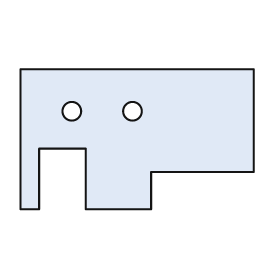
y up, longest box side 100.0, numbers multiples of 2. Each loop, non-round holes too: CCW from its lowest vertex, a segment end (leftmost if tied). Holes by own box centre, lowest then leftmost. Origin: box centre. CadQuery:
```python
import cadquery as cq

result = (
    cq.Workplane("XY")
    .moveTo(-50.0, -30.0)
    .lineTo(-42.0, -30.0)
    .lineTo(-42.0, -4.0)
    .lineTo(-22.0, -4.0)
    .lineTo(-22.0, -30.0)
    .lineTo(6.0, -30.0)
    .lineTo(6.0, -14.0)
    .lineTo(50.0, -14.0)
    .lineTo(50.0, 30.0)
    .lineTo(-50.0, 30.0)
    .close()
    .moveTo(-28.0, 12.0)
    .circle(4.0)
    .moveTo(-2.0, 12.0)
    .circle(4.0)
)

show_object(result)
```